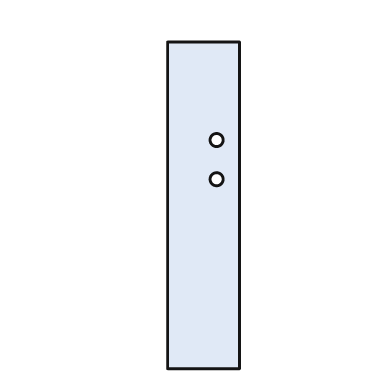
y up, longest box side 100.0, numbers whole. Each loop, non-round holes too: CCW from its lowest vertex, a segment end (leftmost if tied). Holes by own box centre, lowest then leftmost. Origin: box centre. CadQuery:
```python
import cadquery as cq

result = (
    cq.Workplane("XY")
    .moveTo(-11.0, -50.0)
    .lineTo(11.0, -50.0)
    .lineTo(11.0, 50.0)
    .lineTo(-11.0, 50.0)
    .close()
    .moveTo(4.0, 8.0)
    .circle(2.0)
    .moveTo(4.0, 20.0)
    .circle(2.0)
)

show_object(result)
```